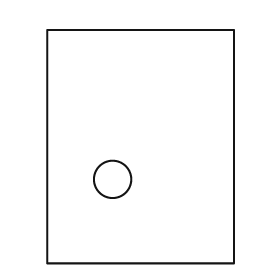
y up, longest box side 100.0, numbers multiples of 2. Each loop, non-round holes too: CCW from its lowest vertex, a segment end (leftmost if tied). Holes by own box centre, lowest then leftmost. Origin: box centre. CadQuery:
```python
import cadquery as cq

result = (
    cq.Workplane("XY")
    .moveTo(-40.0, -50.0)
    .lineTo(40.0, -50.0)
    .lineTo(40.0, 50.0)
    .lineTo(-40.0, 50.0)
    .close()
    .moveTo(-12.0, -14.0)
    .circle(8.0)
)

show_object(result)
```